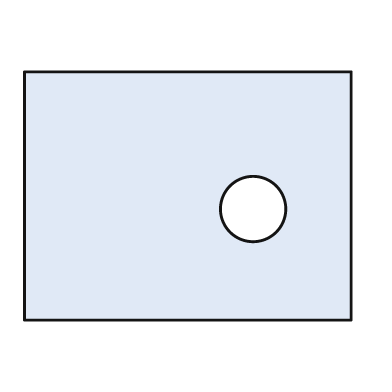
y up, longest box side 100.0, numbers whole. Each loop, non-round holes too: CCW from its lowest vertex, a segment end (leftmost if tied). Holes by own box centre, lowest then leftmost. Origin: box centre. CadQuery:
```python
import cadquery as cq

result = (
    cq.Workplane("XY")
    .moveTo(-50.0, -38.0)
    .lineTo(50.0, -38.0)
    .lineTo(50.0, 38.0)
    .lineTo(-50.0, 38.0)
    .close()
    .moveTo(20.0, -4.0)
    .circle(10.0)
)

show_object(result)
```